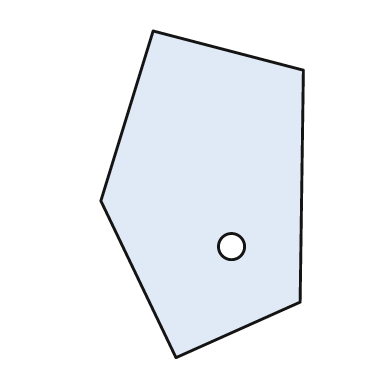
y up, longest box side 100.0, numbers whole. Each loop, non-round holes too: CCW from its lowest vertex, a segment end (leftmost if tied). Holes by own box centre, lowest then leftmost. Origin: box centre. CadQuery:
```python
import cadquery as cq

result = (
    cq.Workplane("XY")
    .moveTo(-8.0, -50.0)
    .lineTo(30.0, -33.0)
    .lineTo(31.0, 38.0)
    .lineTo(-15.0, 50.0)
    .lineTo(-31.0, -2.0)
    .close()
    .moveTo(9.0, -16.0)
    .circle(4.0)
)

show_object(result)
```